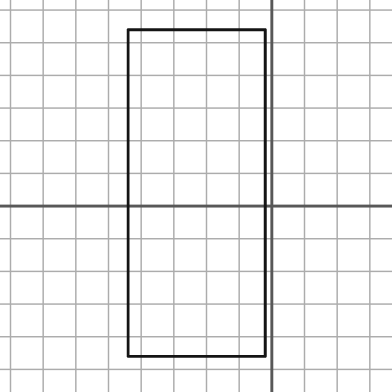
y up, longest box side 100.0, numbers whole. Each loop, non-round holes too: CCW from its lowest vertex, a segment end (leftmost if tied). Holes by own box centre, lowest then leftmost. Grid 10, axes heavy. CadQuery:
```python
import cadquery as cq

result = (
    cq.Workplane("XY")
    .moveTo(-44.0, -46.0)
    .lineTo(-2.0, -46.0)
    .lineTo(-2.0, 54.0)
    .lineTo(-44.0, 54.0)
    .close()
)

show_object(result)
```